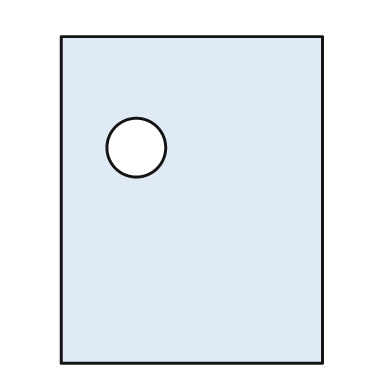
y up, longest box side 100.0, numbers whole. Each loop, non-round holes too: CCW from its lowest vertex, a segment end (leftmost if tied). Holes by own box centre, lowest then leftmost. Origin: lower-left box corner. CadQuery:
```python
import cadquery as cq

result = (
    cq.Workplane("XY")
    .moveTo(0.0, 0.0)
    .lineTo(80.0, 0.0)
    .lineTo(80.0, 100.0)
    .lineTo(0.0, 100.0)
    .close()
    .moveTo(23.0, 66.0)
    .circle(9.0)
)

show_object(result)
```